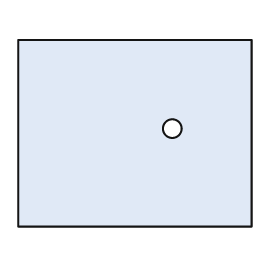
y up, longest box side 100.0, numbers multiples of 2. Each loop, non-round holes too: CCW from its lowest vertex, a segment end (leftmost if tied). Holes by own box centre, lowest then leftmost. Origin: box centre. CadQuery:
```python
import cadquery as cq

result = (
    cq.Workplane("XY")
    .moveTo(-50.0, -40.0)
    .lineTo(50.0, -40.0)
    .lineTo(50.0, 40.0)
    .lineTo(-50.0, 40.0)
    .close()
    .moveTo(16.0, 2.0)
    .circle(4.0)
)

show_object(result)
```